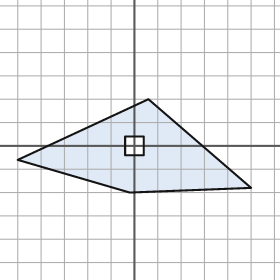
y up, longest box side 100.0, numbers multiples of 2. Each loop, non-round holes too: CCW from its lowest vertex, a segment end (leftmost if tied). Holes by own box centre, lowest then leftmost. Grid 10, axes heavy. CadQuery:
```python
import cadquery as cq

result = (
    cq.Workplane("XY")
    .moveTo(-2.0, -20.0)
    .lineTo(50.0, -18.0)
    .lineTo(6.0, 20.0)
    .lineTo(-50.0, -6.0)
    .close()
    .moveTo(-4.0, -4.0)
    .lineTo(4.0, -4.0)
    .lineTo(4.0, 4.0)
    .lineTo(-4.0, 4.0)
    .close()
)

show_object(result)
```